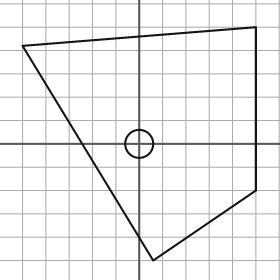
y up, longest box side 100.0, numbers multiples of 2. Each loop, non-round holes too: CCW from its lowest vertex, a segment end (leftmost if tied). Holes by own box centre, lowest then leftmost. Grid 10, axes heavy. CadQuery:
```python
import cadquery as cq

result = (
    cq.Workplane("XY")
    .moveTo(6.0, -50.0)
    .lineTo(50.0, -20.0)
    .lineTo(50.0, 50.0)
    .lineTo(-50.0, 42.0)
    .close()
    .moveTo(0.0, 0.0)
    .circle(6.0)
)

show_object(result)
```